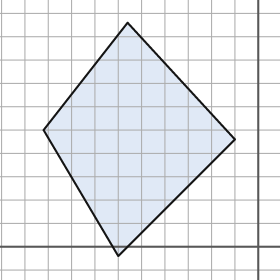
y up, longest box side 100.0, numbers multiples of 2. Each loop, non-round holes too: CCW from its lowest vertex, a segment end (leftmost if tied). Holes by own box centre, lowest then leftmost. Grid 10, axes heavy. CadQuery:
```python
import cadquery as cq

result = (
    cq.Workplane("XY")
    .moveTo(-60.0, -4.0)
    .lineTo(-10.0, 46.0)
    .lineTo(-56.0, 96.0)
    .lineTo(-92.0, 50.0)
    .close()
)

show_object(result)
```